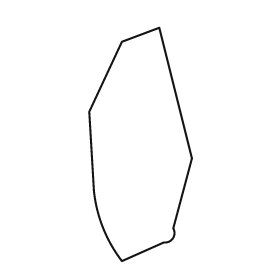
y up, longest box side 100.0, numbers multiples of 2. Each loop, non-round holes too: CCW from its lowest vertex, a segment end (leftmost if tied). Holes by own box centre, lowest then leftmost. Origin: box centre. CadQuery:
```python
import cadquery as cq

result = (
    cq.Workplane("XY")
    .moveTo(-8.0, -50.0)
    .lineTo(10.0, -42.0)
    .threePointArc((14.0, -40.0), (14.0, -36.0))
    .lineTo(22.0, -6.0)
    .lineTo(8.0, 50.0)
    .lineTo(-8.0, 44.0)
    .lineTo(-22.0, 14.0)
    .lineTo(-20.0, -20.0)
    .threePointArc((-16.0, -36.0), (-8.0, -50.0))
    .close()
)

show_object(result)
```